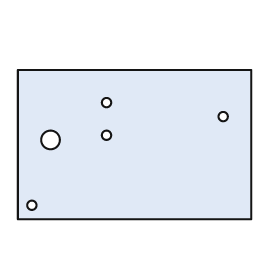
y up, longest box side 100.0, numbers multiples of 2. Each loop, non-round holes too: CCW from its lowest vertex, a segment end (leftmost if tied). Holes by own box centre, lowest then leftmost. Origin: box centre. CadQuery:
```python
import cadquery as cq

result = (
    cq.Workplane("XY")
    .moveTo(-50.0, -32.0)
    .lineTo(50.0, -32.0)
    .lineTo(50.0, 32.0)
    .lineTo(-50.0, 32.0)
    .close()
    .moveTo(-44.0, -26.0)
    .circle(2.0)
    .moveTo(-36.0, 2.0)
    .circle(4.0)
    .moveTo(-12.0, 4.0)
    .circle(2.0)
    .moveTo(38.0, 12.0)
    .circle(2.0)
    .moveTo(-12.0, 18.0)
    .circle(2.0)
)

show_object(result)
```